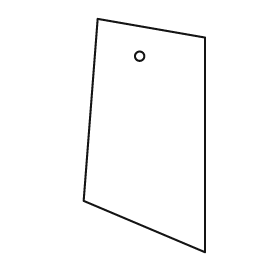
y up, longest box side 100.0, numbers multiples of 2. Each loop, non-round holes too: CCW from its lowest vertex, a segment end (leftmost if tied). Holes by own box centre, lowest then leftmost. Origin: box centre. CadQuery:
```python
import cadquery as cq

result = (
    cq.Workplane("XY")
    .moveTo(26.0, -50.0)
    .lineTo(26.0, 42.0)
    .lineTo(-20.0, 50.0)
    .lineTo(-26.0, -28.0)
    .close()
    .moveTo(-2.0, 34.0)
    .circle(2.0)
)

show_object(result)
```